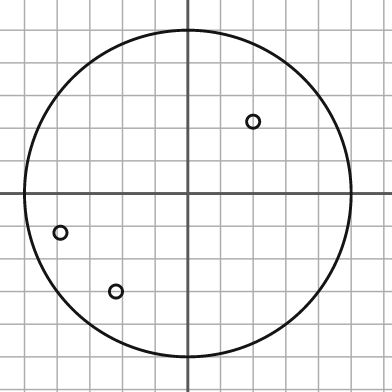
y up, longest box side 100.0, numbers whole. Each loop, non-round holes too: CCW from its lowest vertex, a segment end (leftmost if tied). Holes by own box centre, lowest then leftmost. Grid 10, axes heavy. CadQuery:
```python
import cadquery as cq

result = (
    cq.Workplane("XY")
    .moveTo(0.0, 0.0)
    .circle(50.0)
    .moveTo(-22.0, -30.0)
    .circle(2.0)
    .moveTo(-39.0, -12.0)
    .circle(2.0)
    .moveTo(20.0, 22.0)
    .circle(2.0)
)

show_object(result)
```